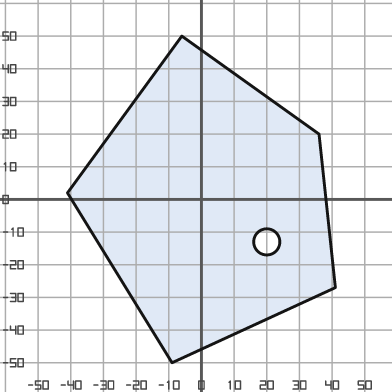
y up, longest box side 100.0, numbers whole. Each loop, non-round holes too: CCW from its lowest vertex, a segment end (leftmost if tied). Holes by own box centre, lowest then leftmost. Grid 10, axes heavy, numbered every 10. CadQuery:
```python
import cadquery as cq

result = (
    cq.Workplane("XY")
    .moveTo(-9.0, -50.0)
    .lineTo(41.0, -27.0)
    .lineTo(36.0, 20.0)
    .lineTo(-6.0, 50.0)
    .lineTo(-41.0, 2.0)
    .close()
    .moveTo(20.0, -13.0)
    .circle(4.0)
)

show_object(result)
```